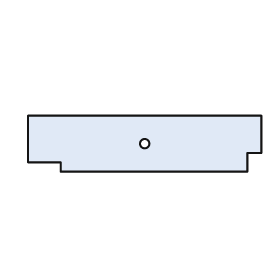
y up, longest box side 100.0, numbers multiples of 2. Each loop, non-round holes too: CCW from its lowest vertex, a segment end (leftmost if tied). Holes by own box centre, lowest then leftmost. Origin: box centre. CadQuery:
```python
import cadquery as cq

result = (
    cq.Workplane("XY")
    .moveTo(-36.0, -12.0)
    .lineTo(44.0, -12.0)
    .lineTo(44.0, -4.0)
    .lineTo(50.0, -4.0)
    .lineTo(50.0, 12.0)
    .lineTo(-50.0, 12.0)
    .lineTo(-50.0, -8.0)
    .lineTo(-36.0, -8.0)
    .close()
    .moveTo(0.0, 0.0)
    .circle(2.0)
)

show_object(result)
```